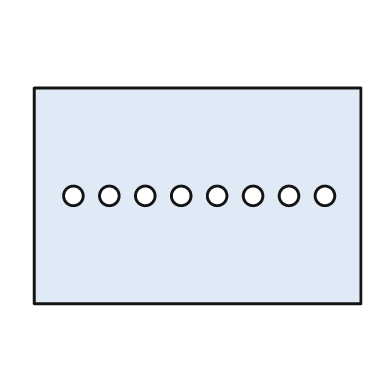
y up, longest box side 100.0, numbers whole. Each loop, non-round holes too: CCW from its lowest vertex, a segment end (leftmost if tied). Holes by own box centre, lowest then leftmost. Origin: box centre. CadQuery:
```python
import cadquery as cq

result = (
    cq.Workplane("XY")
    .moveTo(-50.0, -33.0)
    .lineTo(50.0, -33.0)
    .lineTo(50.0, 33.0)
    .lineTo(-50.0, 33.0)
    .close()
    .moveTo(-38.0, 0.0)
    .circle(3.0)
    .moveTo(-27.0, 0.0)
    .circle(3.0)
    .moveTo(-16.0, 0.0)
    .circle(3.0)
    .moveTo(-5.0, 0.0)
    .circle(3.0)
    .moveTo(6.0, 0.0)
    .circle(3.0)
    .moveTo(17.0, 0.0)
    .circle(3.0)
    .moveTo(28.0, 0.0)
    .circle(3.0)
    .moveTo(39.0, 0.0)
    .circle(3.0)
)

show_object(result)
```